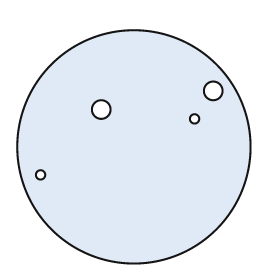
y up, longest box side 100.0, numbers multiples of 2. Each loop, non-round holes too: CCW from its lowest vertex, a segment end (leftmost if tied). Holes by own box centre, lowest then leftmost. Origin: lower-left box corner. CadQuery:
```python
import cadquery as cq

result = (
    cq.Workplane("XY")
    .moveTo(50.0, 50.0)
    .circle(50.0)
    .moveTo(10.0, 38.0)
    .circle(2.0)
    .moveTo(76.0, 62.0)
    .circle(2.0)
    .moveTo(36.0, 66.0)
    .circle(4.0)
    .moveTo(84.0, 74.0)
    .circle(4.0)
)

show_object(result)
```